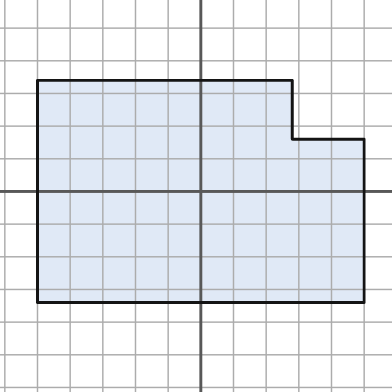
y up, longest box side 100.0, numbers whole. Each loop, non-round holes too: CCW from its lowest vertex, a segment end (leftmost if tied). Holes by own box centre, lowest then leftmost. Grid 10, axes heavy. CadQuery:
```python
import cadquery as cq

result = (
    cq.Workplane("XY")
    .moveTo(-50.0, -34.0)
    .lineTo(50.0, -34.0)
    .lineTo(50.0, 16.0)
    .lineTo(28.0, 16.0)
    .lineTo(28.0, 34.0)
    .lineTo(-50.0, 34.0)
    .close()
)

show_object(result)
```